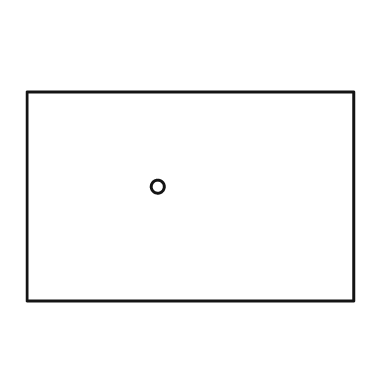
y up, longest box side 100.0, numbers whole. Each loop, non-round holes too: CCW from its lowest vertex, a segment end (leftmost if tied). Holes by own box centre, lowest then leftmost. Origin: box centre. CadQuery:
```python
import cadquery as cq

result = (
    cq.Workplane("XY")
    .moveTo(-50.0, -32.0)
    .lineTo(50.0, -32.0)
    .lineTo(50.0, 32.0)
    .lineTo(-50.0, 32.0)
    .close()
    .moveTo(-10.0, 3.0)
    .circle(2.0)
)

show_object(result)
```